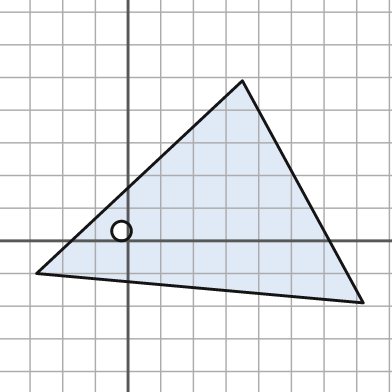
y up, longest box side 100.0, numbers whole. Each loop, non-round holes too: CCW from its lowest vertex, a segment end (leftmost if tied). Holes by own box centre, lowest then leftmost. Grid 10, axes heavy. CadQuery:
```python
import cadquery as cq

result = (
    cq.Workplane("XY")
    .moveTo(72.0, -19.0)
    .lineTo(35.0, 49.0)
    .lineTo(-28.0, -10.0)
    .close()
    .moveTo(-2.0, 3.0)
    .circle(3.0)
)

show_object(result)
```